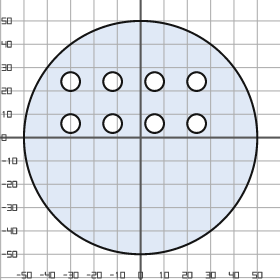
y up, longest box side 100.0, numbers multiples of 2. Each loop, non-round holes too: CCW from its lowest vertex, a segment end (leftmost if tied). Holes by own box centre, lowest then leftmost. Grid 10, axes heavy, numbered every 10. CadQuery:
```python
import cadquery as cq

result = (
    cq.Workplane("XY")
    .moveTo(0.0, 0.0)
    .circle(50.0)
    .moveTo(-30.0, 6.0)
    .circle(4.0)
    .moveTo(-12.0, 6.0)
    .circle(4.0)
    .moveTo(6.0, 6.0)
    .circle(4.0)
    .moveTo(24.0, 6.0)
    .circle(4.0)
    .moveTo(-30.0, 24.0)
    .circle(4.0)
    .moveTo(-12.0, 24.0)
    .circle(4.0)
    .moveTo(6.0, 24.0)
    .circle(4.0)
    .moveTo(24.0, 24.0)
    .circle(4.0)
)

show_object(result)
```